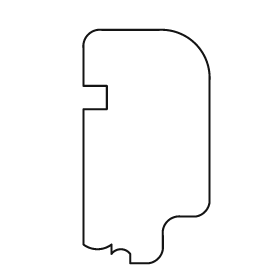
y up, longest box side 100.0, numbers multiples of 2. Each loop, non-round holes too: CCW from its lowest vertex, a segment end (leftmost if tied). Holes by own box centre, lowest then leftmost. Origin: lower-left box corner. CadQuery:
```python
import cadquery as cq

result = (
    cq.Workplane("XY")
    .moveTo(20.0, 0.0)
    .lineTo(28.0, 0.0)
    .threePointArc((32.0, 2.0), (34.0, 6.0))
    .lineTo(34.0, 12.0)
    .threePointArc((36.0, 18.0), (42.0, 20.0))
    .lineTo(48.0, 20.0)
    .threePointArc((52.0, 22.0), (54.0, 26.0))
    .lineTo(54.0, 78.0)
    .threePointArc((48.0, 94.0), (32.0, 100.0))
    .lineTo(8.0, 100.0)
    .threePointArc((2.0, 98.0), (0.0, 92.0))
    .lineTo(0.0, 76.0)
    .lineTo(10.0, 76.0)
    .lineTo(10.0, 66.0)
    .lineTo(0.0, 66.0)
    .lineTo(0.0, 8.0)
    .threePointArc((6.0, 6.0), (12.0, 8.0))
    .lineTo(12.0, 4.0)
    .threePointArc((16.0, 6.0), (20.0, 4.0))
    .close()
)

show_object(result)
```